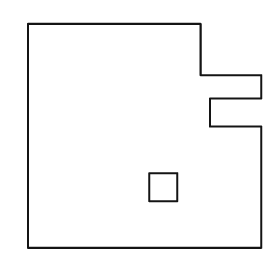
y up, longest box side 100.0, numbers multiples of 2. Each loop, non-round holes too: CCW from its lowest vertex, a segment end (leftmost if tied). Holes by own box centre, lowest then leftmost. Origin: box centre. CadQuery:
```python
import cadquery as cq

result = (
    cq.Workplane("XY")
    .moveTo(-50.0, -48.0)
    .lineTo(50.0, -48.0)
    .lineTo(50.0, 4.0)
    .lineTo(28.0, 4.0)
    .lineTo(28.0, 16.0)
    .lineTo(50.0, 16.0)
    .lineTo(50.0, 26.0)
    .lineTo(24.0, 26.0)
    .lineTo(24.0, 48.0)
    .lineTo(-50.0, 48.0)
    .close()
    .moveTo(2.0, -28.0)
    .lineTo(14.0, -28.0)
    .lineTo(14.0, -16.0)
    .lineTo(2.0, -16.0)
    .close()
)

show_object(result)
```